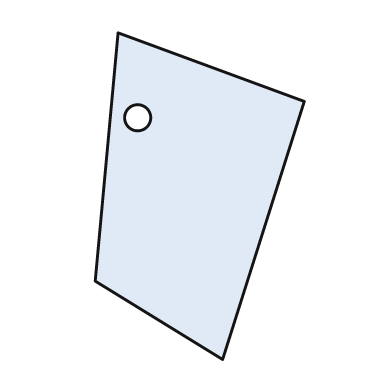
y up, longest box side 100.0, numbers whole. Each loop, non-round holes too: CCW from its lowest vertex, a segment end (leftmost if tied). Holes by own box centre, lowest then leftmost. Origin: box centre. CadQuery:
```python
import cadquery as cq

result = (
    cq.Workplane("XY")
    .moveTo(7.0, -50.0)
    .lineTo(32.0, 29.0)
    .lineTo(-25.0, 50.0)
    .lineTo(-32.0, -26.0)
    .close()
    .moveTo(-19.0, 24.0)
    .circle(4.0)
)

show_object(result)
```